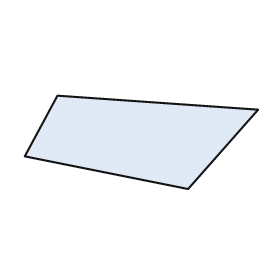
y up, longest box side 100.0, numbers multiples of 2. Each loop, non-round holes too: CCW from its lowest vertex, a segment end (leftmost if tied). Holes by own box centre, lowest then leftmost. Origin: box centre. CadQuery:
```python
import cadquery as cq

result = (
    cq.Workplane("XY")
    .moveTo(20.0, -20.0)
    .lineTo(50.0, 14.0)
    .lineTo(-36.0, 20.0)
    .lineTo(-50.0, -6.0)
    .close()
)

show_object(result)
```